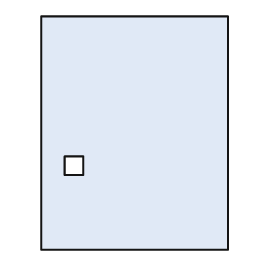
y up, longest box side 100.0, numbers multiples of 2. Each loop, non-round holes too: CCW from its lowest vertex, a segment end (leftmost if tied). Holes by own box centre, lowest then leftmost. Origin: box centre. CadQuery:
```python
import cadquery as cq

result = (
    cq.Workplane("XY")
    .moveTo(-40.0, -50.0)
    .lineTo(40.0, -50.0)
    .lineTo(40.0, 50.0)
    .lineTo(-40.0, 50.0)
    .close()
    .moveTo(-30.0, -18.0)
    .lineTo(-22.0, -18.0)
    .lineTo(-22.0, -10.0)
    .lineTo(-30.0, -10.0)
    .close()
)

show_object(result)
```